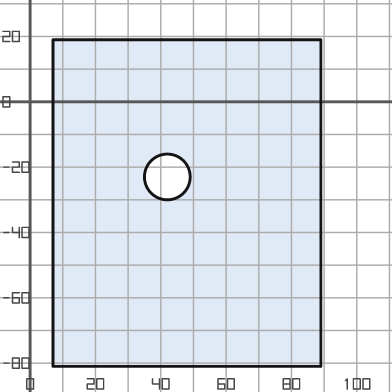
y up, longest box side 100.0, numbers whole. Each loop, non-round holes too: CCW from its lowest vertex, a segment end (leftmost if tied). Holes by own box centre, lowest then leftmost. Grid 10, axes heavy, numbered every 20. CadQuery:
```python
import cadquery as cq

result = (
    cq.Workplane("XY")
    .moveTo(7.0, -81.0)
    .lineTo(89.0, -81.0)
    .lineTo(89.0, 19.0)
    .lineTo(7.0, 19.0)
    .close()
    .moveTo(42.0, -23.0)
    .circle(7.0)
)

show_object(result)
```